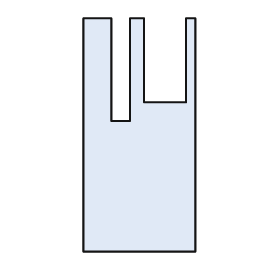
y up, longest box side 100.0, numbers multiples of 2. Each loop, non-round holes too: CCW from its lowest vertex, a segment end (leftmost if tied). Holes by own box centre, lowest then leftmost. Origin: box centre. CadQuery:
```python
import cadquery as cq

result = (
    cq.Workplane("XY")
    .moveTo(-24.0, -50.0)
    .lineTo(24.0, -50.0)
    .lineTo(24.0, 50.0)
    .lineTo(20.0, 50.0)
    .lineTo(20.0, 14.0)
    .lineTo(2.0, 14.0)
    .lineTo(2.0, 50.0)
    .lineTo(-4.0, 50.0)
    .lineTo(-4.0, 6.0)
    .lineTo(-12.0, 6.0)
    .lineTo(-12.0, 50.0)
    .lineTo(-24.0, 50.0)
    .close()
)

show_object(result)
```